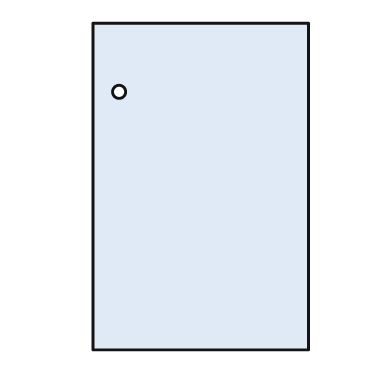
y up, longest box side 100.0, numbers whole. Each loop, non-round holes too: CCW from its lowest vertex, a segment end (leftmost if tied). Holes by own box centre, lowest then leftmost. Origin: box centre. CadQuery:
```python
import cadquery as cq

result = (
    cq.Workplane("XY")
    .moveTo(-33.0, -50.0)
    .lineTo(33.0, -50.0)
    .lineTo(33.0, 50.0)
    .lineTo(-33.0, 50.0)
    .close()
    .moveTo(-25.0, 29.0)
    .circle(2.0)
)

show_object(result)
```